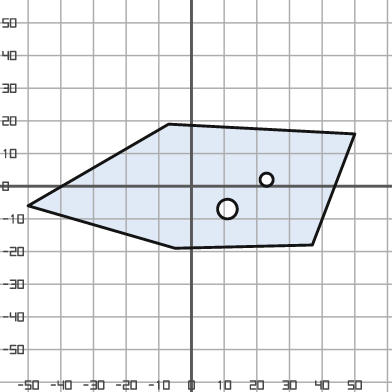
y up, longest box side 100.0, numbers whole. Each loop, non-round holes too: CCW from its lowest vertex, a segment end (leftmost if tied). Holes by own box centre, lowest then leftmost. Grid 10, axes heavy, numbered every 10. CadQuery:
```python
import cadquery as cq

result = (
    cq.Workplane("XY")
    .moveTo(-5.0, -19.0)
    .lineTo(37.0, -18.0)
    .lineTo(50.0, 16.0)
    .lineTo(-7.0, 19.0)
    .lineTo(-50.0, -6.0)
    .close()
    .moveTo(11.0, -7.0)
    .circle(3.0)
    .moveTo(23.0, 2.0)
    .circle(2.0)
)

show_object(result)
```